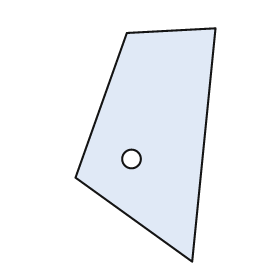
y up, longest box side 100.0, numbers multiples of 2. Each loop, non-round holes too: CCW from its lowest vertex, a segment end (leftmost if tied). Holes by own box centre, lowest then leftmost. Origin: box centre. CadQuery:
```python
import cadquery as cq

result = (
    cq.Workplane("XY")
    .moveTo(20.0, -50.0)
    .lineTo(30.0, 50.0)
    .lineTo(-8.0, 48.0)
    .lineTo(-30.0, -14.0)
    .close()
    .moveTo(-6.0, -6.0)
    .circle(4.0)
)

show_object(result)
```